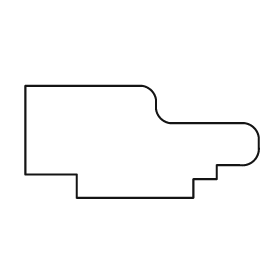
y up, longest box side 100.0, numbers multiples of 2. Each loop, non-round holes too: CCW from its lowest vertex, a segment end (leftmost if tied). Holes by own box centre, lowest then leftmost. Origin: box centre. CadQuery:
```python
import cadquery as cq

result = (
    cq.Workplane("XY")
    .moveTo(-28.0, -24.0)
    .lineTo(22.0, -24.0)
    .lineTo(22.0, -16.0)
    .lineTo(32.0, -16.0)
    .lineTo(32.0, -10.0)
    .lineTo(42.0, -10.0)
    .threePointArc((48.0, -8.0), (50.0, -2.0))
    .lineTo(50.0, 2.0)
    .threePointArc((48.0, 6.0), (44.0, 8.0))
    .lineTo(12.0, 8.0)
    .threePointArc((8.0, 10.0), (6.0, 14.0))
    .lineTo(6.0, 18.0)
    .threePointArc((4.0, 22.0), (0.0, 24.0))
    .lineTo(-50.0, 24.0)
    .lineTo(-50.0, -14.0)
    .lineTo(-28.0, -14.0)
    .close()
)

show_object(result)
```